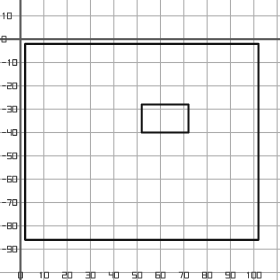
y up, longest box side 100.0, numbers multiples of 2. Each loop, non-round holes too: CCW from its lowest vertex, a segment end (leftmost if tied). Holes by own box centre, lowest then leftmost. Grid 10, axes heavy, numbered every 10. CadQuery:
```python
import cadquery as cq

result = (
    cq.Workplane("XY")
    .moveTo(2.0, -86.0)
    .lineTo(102.0, -86.0)
    .lineTo(102.0, -2.0)
    .lineTo(2.0, -2.0)
    .close()
    .moveTo(52.0, -40.0)
    .lineTo(72.0, -40.0)
    .lineTo(72.0, -28.0)
    .lineTo(52.0, -28.0)
    .close()
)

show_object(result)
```